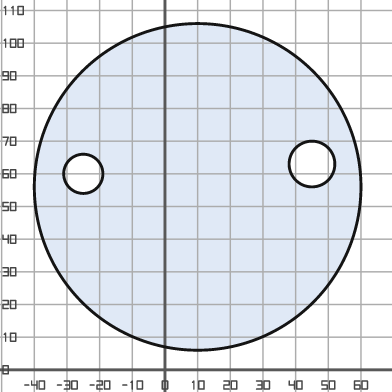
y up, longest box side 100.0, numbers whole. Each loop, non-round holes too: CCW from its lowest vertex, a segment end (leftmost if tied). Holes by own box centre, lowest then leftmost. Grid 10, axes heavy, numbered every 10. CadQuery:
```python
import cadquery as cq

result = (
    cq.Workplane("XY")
    .moveTo(10.0, 56.0)
    .circle(50.0)
    .moveTo(-25.0, 60.0)
    .circle(6.0)
    .moveTo(45.0, 63.0)
    .circle(7.0)
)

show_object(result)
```